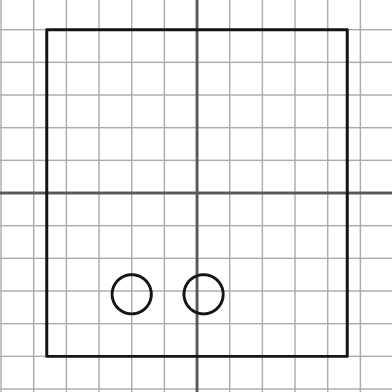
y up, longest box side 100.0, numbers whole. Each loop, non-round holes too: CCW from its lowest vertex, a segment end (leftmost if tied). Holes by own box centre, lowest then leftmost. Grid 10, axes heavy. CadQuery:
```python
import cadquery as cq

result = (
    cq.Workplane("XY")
    .moveTo(-46.0, -50.0)
    .lineTo(46.0, -50.0)
    .lineTo(46.0, 50.0)
    .lineTo(-46.0, 50.0)
    .close()
    .moveTo(-20.0, -31.0)
    .circle(6.0)
    .moveTo(2.0, -31.0)
    .circle(6.0)
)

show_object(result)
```